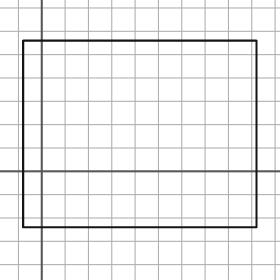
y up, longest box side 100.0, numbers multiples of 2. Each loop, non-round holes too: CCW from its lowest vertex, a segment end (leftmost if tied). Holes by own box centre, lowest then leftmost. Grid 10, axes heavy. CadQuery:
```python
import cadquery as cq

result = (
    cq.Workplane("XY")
    .moveTo(-8.0, -24.0)
    .lineTo(92.0, -24.0)
    .lineTo(92.0, 56.0)
    .lineTo(-8.0, 56.0)
    .close()
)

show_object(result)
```